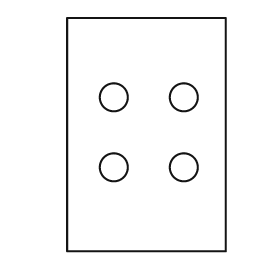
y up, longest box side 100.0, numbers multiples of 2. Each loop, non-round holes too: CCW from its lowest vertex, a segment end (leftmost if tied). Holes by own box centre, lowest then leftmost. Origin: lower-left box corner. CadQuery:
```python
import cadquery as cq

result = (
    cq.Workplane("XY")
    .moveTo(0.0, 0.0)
    .lineTo(68.0, 0.0)
    .lineTo(68.0, 100.0)
    .lineTo(0.0, 100.0)
    .close()
    .moveTo(20.0, 36.0)
    .circle(6.0)
    .moveTo(50.0, 36.0)
    .circle(6.0)
    .moveTo(20.0, 66.0)
    .circle(6.0)
    .moveTo(50.0, 66.0)
    .circle(6.0)
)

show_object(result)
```